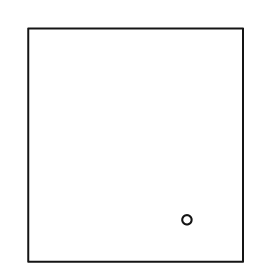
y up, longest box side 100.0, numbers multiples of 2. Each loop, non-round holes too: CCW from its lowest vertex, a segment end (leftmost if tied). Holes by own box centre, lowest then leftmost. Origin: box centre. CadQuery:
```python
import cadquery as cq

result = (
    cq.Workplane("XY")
    .moveTo(-46.0, -50.0)
    .lineTo(46.0, -50.0)
    .lineTo(46.0, 50.0)
    .lineTo(-46.0, 50.0)
    .close()
    .moveTo(22.0, -32.0)
    .circle(2.0)
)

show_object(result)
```